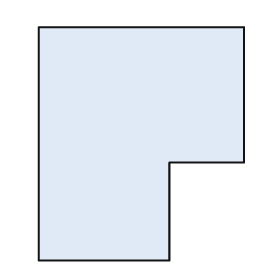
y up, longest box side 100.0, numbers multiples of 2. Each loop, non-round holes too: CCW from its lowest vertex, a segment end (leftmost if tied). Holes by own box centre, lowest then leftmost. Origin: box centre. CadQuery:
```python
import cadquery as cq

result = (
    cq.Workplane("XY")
    .moveTo(-44.0, -50.0)
    .lineTo(12.0, -50.0)
    .lineTo(12.0, -8.0)
    .lineTo(44.0, -8.0)
    .lineTo(44.0, 50.0)
    .lineTo(-44.0, 50.0)
    .close()
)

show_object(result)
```